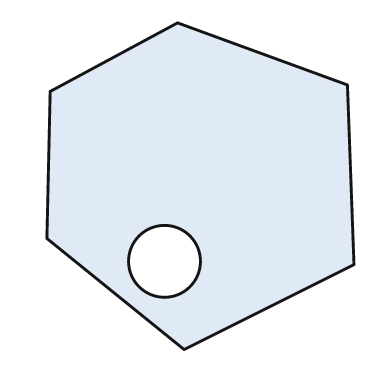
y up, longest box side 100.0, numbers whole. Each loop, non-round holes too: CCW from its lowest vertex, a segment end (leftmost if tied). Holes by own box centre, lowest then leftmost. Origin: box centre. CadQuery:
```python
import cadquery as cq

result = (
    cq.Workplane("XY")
    .moveTo(-5.0, -50.0)
    .lineTo(47.0, -24.0)
    .lineTo(45.0, 31.0)
    .lineTo(-7.0, 50.0)
    .lineTo(-46.0, 29.0)
    .lineTo(-47.0, -16.0)
    .close()
    .moveTo(-11.0, -23.0)
    .circle(11.0)
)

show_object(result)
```